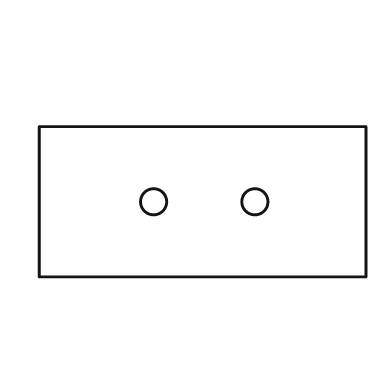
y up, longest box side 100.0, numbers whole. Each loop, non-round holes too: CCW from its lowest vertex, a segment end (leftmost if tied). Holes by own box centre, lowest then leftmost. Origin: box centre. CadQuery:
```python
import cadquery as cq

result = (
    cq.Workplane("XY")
    .moveTo(-50.0, -23.0)
    .lineTo(50.0, -23.0)
    .lineTo(50.0, 23.0)
    .lineTo(-50.0, 23.0)
    .close()
    .moveTo(-15.0, 0.0)
    .circle(4.0)
    .moveTo(16.0, 0.0)
    .circle(4.0)
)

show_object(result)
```